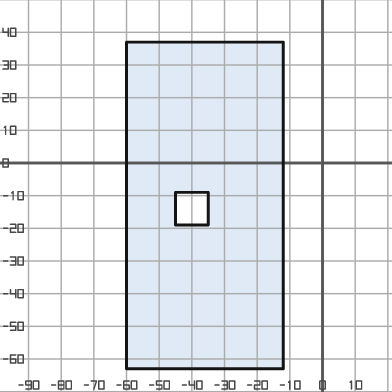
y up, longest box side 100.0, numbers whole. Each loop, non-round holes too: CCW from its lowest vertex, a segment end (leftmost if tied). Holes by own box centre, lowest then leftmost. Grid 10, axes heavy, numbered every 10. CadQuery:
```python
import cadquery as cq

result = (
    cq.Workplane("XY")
    .moveTo(-60.0, -63.0)
    .lineTo(-12.0, -63.0)
    .lineTo(-12.0, 37.0)
    .lineTo(-60.0, 37.0)
    .close()
    .moveTo(-45.0, -19.0)
    .lineTo(-35.0, -19.0)
    .lineTo(-35.0, -9.0)
    .lineTo(-45.0, -9.0)
    .close()
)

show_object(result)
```